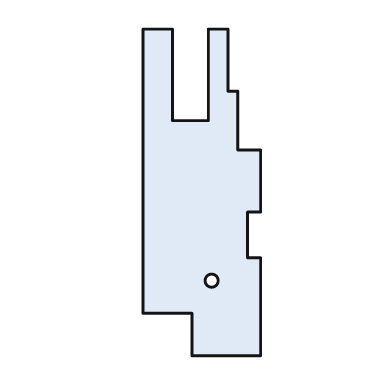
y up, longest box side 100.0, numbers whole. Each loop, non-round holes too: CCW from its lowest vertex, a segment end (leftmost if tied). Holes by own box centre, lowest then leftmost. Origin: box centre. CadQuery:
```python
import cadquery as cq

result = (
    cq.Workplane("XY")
    .moveTo(-3.0, -50.0)
    .lineTo(18.0, -50.0)
    .lineTo(18.0, -20.0)
    .lineTo(14.0, -20.0)
    .lineTo(14.0, -6.0)
    .lineTo(18.0, -6.0)
    .lineTo(18.0, 13.0)
    .lineTo(11.0, 13.0)
    .lineTo(11.0, 31.0)
    .lineTo(8.0, 31.0)
    .lineTo(8.0, 50.0)
    .lineTo(2.0, 50.0)
    .lineTo(2.0, 22.0)
    .lineTo(-9.0, 22.0)
    .lineTo(-9.0, 50.0)
    .lineTo(-18.0, 50.0)
    .lineTo(-18.0, -37.0)
    .lineTo(-3.0, -37.0)
    .close()
    .moveTo(3.0, -27.0)
    .circle(2.0)
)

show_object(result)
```